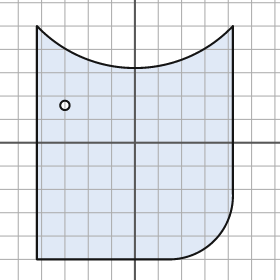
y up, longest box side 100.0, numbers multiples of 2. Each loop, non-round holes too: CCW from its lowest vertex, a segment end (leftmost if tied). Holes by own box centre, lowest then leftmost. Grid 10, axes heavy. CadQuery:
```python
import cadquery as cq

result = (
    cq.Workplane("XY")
    .moveTo(-42.0, -50.0)
    .lineTo(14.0, -50.0)
    .threePointArc((34.0, -42.0), (42.0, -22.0))
    .lineTo(42.0, 50.0)
    .threePointArc((0.0, 32.0), (-42.0, 50.0))
    .close()
    .moveTo(-30.0, 16.0)
    .circle(2.0)
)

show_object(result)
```